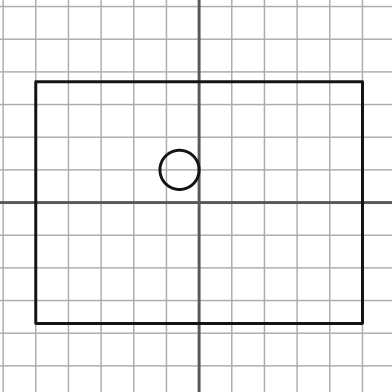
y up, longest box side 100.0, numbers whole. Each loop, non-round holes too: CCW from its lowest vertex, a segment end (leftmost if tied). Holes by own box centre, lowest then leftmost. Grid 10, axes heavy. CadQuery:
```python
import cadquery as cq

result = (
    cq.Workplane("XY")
    .moveTo(-50.0, -37.0)
    .lineTo(50.0, -37.0)
    .lineTo(50.0, 37.0)
    .lineTo(-50.0, 37.0)
    .close()
    .moveTo(-6.0, 10.0)
    .circle(6.0)
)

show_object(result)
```